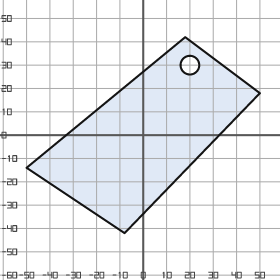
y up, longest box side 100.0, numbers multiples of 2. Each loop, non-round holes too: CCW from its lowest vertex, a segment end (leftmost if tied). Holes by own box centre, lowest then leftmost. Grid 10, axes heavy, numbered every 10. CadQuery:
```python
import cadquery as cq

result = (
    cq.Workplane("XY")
    .moveTo(-8.0, -42.0)
    .lineTo(50.0, 18.0)
    .lineTo(18.0, 42.0)
    .lineTo(-50.0, -14.0)
    .close()
    .moveTo(20.0, 30.0)
    .circle(4.0)
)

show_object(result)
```